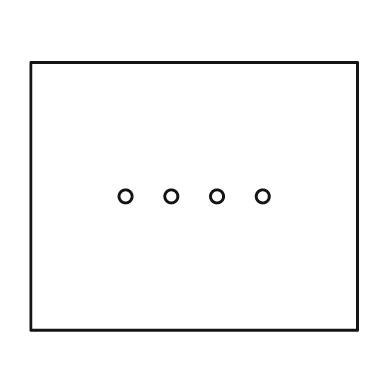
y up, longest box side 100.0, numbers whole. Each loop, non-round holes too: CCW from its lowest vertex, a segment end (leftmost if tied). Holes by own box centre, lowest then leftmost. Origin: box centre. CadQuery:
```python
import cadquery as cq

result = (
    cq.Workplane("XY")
    .moveTo(-50.0, -41.0)
    .lineTo(50.0, -41.0)
    .lineTo(50.0, 41.0)
    .lineTo(-50.0, 41.0)
    .close()
    .moveTo(-21.0, 0.0)
    .circle(2.0)
    .moveTo(-7.0, 0.0)
    .circle(2.0)
    .moveTo(7.0, 0.0)
    .circle(2.0)
    .moveTo(21.0, 0.0)
    .circle(2.0)
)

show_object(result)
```